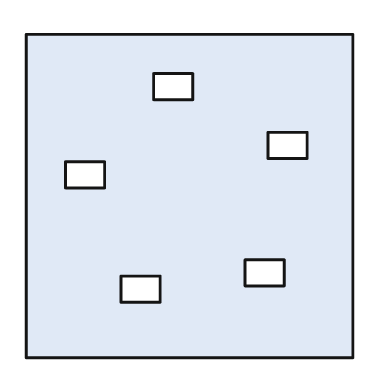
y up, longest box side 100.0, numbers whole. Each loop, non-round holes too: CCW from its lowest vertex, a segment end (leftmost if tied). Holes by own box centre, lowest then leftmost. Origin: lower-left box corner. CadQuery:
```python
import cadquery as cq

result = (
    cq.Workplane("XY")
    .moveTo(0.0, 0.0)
    .lineTo(100.0, 0.0)
    .lineTo(100.0, 99.0)
    .lineTo(0.0, 99.0)
    .close()
    .moveTo(29.0, 17.0)
    .lineTo(41.0, 17.0)
    .lineTo(41.0, 25.0)
    .lineTo(29.0, 25.0)
    .close()
    .moveTo(67.0, 22.0)
    .lineTo(79.0, 22.0)
    .lineTo(79.0, 30.0)
    .lineTo(67.0, 30.0)
    .close()
    .moveTo(12.0, 52.0)
    .lineTo(24.0, 52.0)
    .lineTo(24.0, 60.0)
    .lineTo(12.0, 60.0)
    .close()
    .moveTo(74.0, 61.0)
    .lineTo(86.0, 61.0)
    .lineTo(86.0, 69.0)
    .lineTo(74.0, 69.0)
    .close()
    .moveTo(39.0, 79.0)
    .lineTo(51.0, 79.0)
    .lineTo(51.0, 87.0)
    .lineTo(39.0, 87.0)
    .close()
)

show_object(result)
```